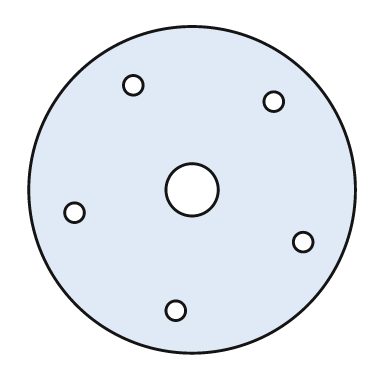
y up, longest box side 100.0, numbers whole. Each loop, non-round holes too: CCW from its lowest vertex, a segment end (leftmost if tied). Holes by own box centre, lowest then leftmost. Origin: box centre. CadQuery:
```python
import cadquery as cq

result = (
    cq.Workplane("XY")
    .moveTo(0.0, 0.0)
    .circle(50.0)
    .moveTo(-5.0, -37.0)
    .circle(3.0)
    .moveTo(34.0, -16.0)
    .circle(3.0)
    .moveTo(-36.0, -7.0)
    .circle(3.0)
    .moveTo(0.0, 0.0)
    .circle(8.0)
    .moveTo(25.0, 27.0)
    .circle(3.0)
    .moveTo(-18.0, 32.0)
    .circle(3.0)
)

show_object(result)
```